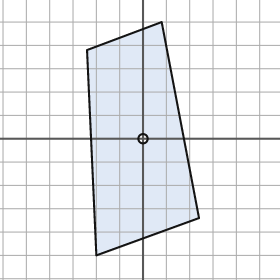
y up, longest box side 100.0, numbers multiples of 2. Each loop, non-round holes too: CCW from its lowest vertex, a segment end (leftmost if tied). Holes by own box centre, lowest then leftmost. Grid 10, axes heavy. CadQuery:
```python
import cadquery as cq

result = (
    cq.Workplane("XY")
    .moveTo(-20.0, -50.0)
    .lineTo(24.0, -34.0)
    .lineTo(8.0, 50.0)
    .lineTo(-24.0, 38.0)
    .close()
    .moveTo(0.0, 0.0)
    .circle(2.0)
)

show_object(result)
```